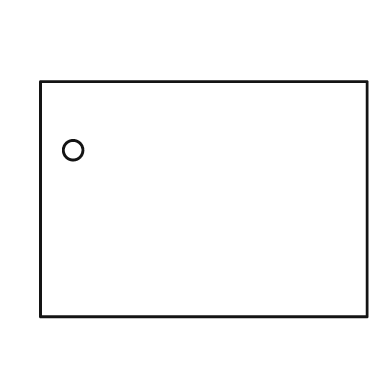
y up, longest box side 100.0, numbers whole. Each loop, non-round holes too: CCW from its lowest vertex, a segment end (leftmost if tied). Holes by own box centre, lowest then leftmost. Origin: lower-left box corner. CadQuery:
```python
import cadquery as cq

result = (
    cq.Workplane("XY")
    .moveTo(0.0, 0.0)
    .lineTo(100.0, 0.0)
    .lineTo(100.0, 72.0)
    .lineTo(0.0, 72.0)
    .close()
    .moveTo(10.0, 51.0)
    .circle(3.0)
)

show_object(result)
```